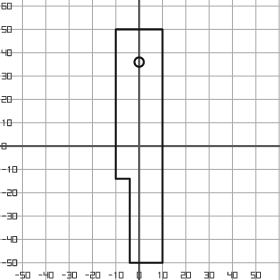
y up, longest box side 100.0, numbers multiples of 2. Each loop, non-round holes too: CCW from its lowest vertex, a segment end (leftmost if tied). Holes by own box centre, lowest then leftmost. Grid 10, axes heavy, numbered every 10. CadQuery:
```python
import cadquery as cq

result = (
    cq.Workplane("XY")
    .moveTo(-4.0, -50.0)
    .lineTo(10.0, -50.0)
    .lineTo(10.0, 50.0)
    .lineTo(-10.0, 50.0)
    .lineTo(-10.0, -14.0)
    .lineTo(-4.0, -14.0)
    .close()
    .moveTo(0.0, 36.0)
    .circle(2.0)
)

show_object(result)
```